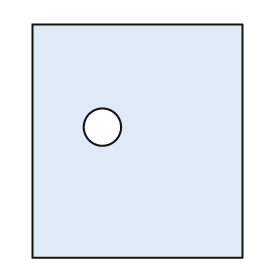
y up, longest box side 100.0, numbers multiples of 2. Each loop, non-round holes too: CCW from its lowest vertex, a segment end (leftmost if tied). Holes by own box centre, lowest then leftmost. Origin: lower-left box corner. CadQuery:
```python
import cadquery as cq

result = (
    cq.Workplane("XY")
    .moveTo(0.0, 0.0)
    .lineTo(90.0, 0.0)
    .lineTo(90.0, 100.0)
    .lineTo(0.0, 100.0)
    .close()
    .moveTo(30.0, 56.0)
    .circle(8.0)
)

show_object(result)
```